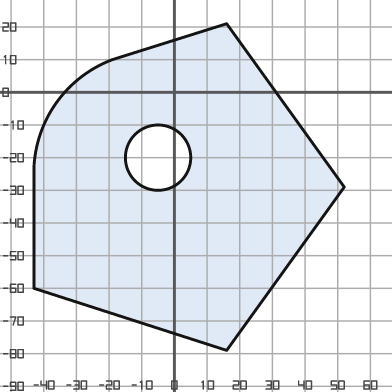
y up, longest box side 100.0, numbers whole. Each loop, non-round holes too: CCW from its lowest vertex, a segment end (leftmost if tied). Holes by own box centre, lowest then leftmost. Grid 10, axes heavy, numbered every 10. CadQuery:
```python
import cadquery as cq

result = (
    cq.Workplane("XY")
    .moveTo(16.0, -79.0)
    .lineTo(52.0, -29.0)
    .lineTo(16.0, 21.0)
    .lineTo(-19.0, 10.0)
    .threePointArc((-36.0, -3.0), (-43.0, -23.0))
    .lineTo(-43.0, -60.0)
    .close()
    .moveTo(-5.0, -20.0)
    .circle(10.0)
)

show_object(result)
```